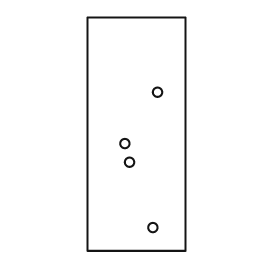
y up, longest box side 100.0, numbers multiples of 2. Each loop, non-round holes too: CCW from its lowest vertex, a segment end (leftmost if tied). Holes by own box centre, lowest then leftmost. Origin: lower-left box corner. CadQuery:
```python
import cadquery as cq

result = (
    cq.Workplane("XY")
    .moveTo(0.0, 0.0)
    .lineTo(42.0, 0.0)
    .lineTo(42.0, 100.0)
    .lineTo(0.0, 100.0)
    .close()
    .moveTo(28.0, 10.0)
    .circle(2.0)
    .moveTo(18.0, 38.0)
    .circle(2.0)
    .moveTo(16.0, 46.0)
    .circle(2.0)
    .moveTo(30.0, 68.0)
    .circle(2.0)
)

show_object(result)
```